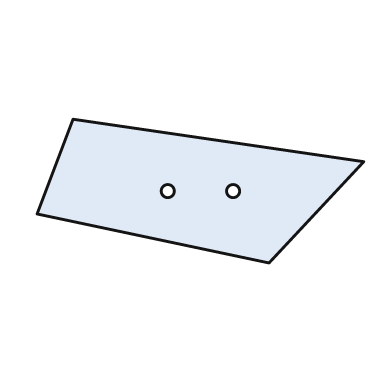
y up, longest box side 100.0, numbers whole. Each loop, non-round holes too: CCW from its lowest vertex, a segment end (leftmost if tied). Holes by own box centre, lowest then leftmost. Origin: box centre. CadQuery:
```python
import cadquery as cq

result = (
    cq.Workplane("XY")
    .moveTo(21.0, -22.0)
    .lineTo(50.0, 9.0)
    .lineTo(-39.0, 22.0)
    .lineTo(-50.0, -7.0)
    .close()
    .moveTo(-10.0, 0.0)
    .circle(2.0)
    .moveTo(10.0, 0.0)
    .circle(2.0)
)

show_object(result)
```